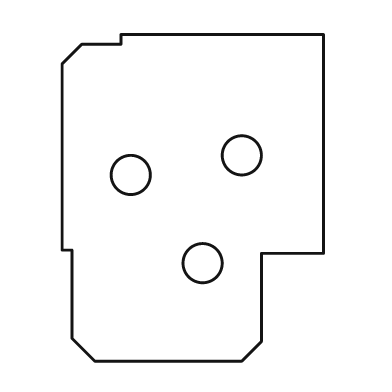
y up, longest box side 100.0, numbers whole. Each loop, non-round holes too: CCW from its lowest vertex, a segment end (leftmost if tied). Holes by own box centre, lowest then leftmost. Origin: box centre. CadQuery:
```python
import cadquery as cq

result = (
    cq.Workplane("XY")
    .moveTo(-30.0, -50.0)
    .lineTo(15.0, -50.0)
    .lineTo(21.0, -44.0)
    .lineTo(21.0, -17.0)
    .lineTo(40.0, -17.0)
    .lineTo(40.0, 50.0)
    .lineTo(-22.0, 50.0)
    .lineTo(-22.0, 47.0)
    .lineTo(-34.0, 47.0)
    .lineTo(-40.0, 41.0)
    .lineTo(-40.0, -16.0)
    .lineTo(-37.0, -16.0)
    .lineTo(-37.0, -43.0)
    .close()
    .moveTo(3.0, -20.0)
    .circle(6.0)
    .moveTo(-19.0, 7.0)
    .circle(6.0)
    .moveTo(15.0, 13.0)
    .circle(6.0)
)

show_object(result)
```